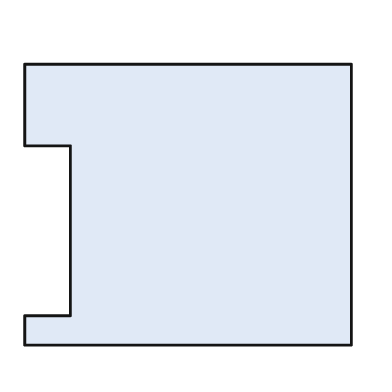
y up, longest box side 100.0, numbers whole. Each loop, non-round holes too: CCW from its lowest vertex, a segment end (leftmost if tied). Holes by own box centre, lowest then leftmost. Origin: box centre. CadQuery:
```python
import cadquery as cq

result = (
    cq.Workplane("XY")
    .moveTo(-50.0, -43.0)
    .lineTo(50.0, -43.0)
    .lineTo(50.0, 43.0)
    .lineTo(-50.0, 43.0)
    .lineTo(-50.0, 18.0)
    .lineTo(-36.0, 18.0)
    .lineTo(-36.0, -34.0)
    .lineTo(-50.0, -34.0)
    .close()
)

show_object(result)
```